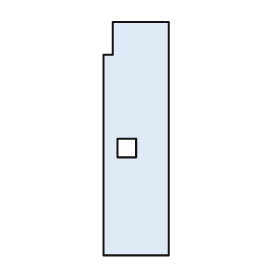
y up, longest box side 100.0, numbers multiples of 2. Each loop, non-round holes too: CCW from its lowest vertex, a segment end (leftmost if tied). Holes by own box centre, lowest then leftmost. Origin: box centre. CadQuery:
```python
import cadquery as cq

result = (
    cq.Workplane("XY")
    .moveTo(-14.0, -50.0)
    .lineTo(14.0, -50.0)
    .lineTo(14.0, 50.0)
    .lineTo(-10.0, 50.0)
    .lineTo(-10.0, 36.0)
    .lineTo(-14.0, 36.0)
    .close()
    .moveTo(-8.0, -8.0)
    .lineTo(0.0, -8.0)
    .lineTo(0.0, 0.0)
    .lineTo(-8.0, 0.0)
    .close()
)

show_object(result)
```